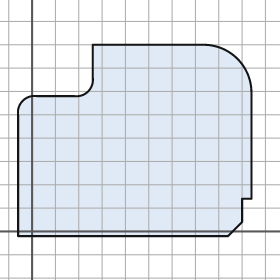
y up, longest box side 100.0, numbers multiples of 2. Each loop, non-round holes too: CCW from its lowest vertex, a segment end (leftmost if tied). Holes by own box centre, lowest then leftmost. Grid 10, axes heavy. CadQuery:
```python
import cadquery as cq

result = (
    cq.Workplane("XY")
    .moveTo(-6.0, -2.0)
    .lineTo(84.0, -2.0)
    .lineTo(90.0, 4.0)
    .lineTo(90.0, 14.0)
    .lineTo(94.0, 14.0)
    .lineTo(94.0, 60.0)
    .threePointArc((88.0, 74.0), (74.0, 80.0))
    .lineTo(26.0, 80.0)
    .lineTo(26.0, 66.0)
    .threePointArc((24.0, 60.0), (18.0, 58.0))
    .lineTo(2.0, 58.0)
    .threePointArc((-4.0, 56.0), (-6.0, 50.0))
    .close()
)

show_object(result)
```